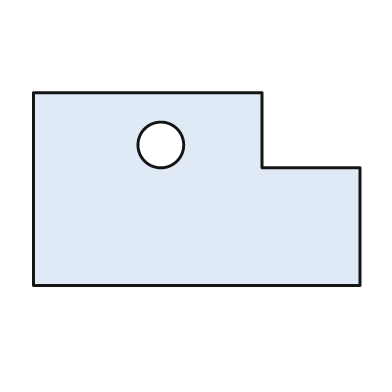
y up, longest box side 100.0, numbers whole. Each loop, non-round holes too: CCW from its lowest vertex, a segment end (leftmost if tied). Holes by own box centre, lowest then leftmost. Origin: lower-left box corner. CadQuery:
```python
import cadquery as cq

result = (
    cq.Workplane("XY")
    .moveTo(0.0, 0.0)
    .lineTo(100.0, 0.0)
    .lineTo(100.0, 36.0)
    .lineTo(70.0, 36.0)
    .lineTo(70.0, 59.0)
    .lineTo(0.0, 59.0)
    .close()
    .moveTo(39.0, 43.0)
    .circle(7.0)
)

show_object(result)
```